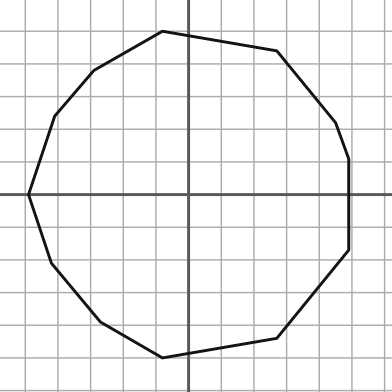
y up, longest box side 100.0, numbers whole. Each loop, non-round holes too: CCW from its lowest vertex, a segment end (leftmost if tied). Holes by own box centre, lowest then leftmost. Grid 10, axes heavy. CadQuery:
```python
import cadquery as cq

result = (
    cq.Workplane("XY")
    .moveTo(-8.0, -50.0)
    .lineTo(27.0, -44.0)
    .lineTo(49.0, -17.0)
    .lineTo(49.0, 11.0)
    .lineTo(45.0, 22.0)
    .lineTo(27.0, 44.0)
    .lineTo(-8.0, 50.0)
    .lineTo(-29.0, 38.0)
    .lineTo(-41.0, 24.0)
    .lineTo(-49.0, 0.0)
    .lineTo(-42.0, -21.0)
    .lineTo(-27.0, -39.0)
    .close()
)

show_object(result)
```